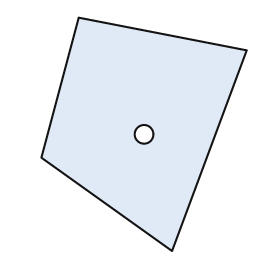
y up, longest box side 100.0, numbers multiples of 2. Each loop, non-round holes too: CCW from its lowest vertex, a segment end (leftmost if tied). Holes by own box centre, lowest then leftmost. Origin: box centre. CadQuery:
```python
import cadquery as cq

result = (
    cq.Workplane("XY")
    .moveTo(12.0, -50.0)
    .lineTo(44.0, 36.0)
    .lineTo(-28.0, 50.0)
    .lineTo(-44.0, -10.0)
    .close()
    .moveTo(0.0, 0.0)
    .circle(4.0)
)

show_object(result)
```